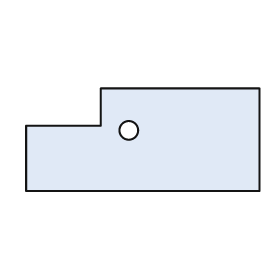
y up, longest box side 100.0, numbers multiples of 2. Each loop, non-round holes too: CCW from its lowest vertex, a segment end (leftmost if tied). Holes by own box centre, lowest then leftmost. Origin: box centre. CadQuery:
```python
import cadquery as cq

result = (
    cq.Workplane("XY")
    .moveTo(-50.0, -22.0)
    .lineTo(50.0, -22.0)
    .lineTo(50.0, 22.0)
    .lineTo(-18.0, 22.0)
    .lineTo(-18.0, 6.0)
    .lineTo(-50.0, 6.0)
    .close()
    .moveTo(-6.0, 4.0)
    .circle(4.0)
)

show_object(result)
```